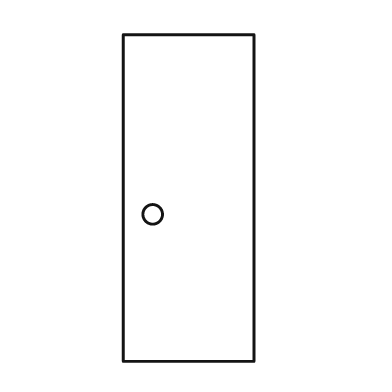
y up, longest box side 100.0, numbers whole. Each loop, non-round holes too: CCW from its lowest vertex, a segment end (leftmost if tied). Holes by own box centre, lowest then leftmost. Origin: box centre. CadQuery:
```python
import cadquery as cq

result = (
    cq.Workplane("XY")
    .moveTo(-20.0, -50.0)
    .lineTo(20.0, -50.0)
    .lineTo(20.0, 50.0)
    .lineTo(-20.0, 50.0)
    .close()
    .moveTo(-11.0, -5.0)
    .circle(3.0)
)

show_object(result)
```